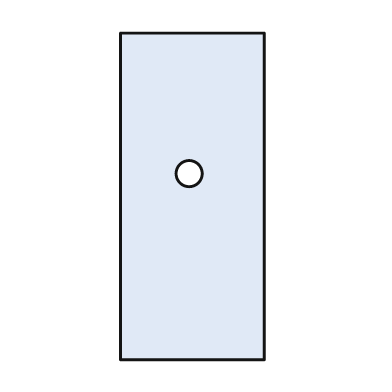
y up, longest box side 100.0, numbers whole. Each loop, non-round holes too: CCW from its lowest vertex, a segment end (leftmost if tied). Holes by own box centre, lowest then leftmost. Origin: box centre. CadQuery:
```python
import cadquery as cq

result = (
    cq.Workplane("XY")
    .moveTo(-22.0, -50.0)
    .lineTo(22.0, -50.0)
    .lineTo(22.0, 50.0)
    .lineTo(-22.0, 50.0)
    .close()
    .moveTo(-1.0, 7.0)
    .circle(4.0)
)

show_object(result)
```